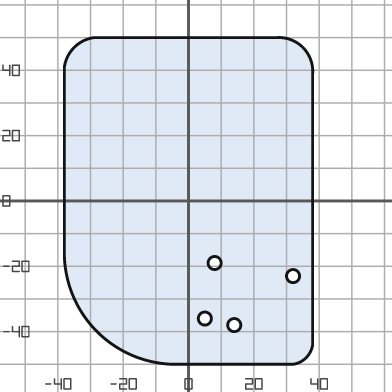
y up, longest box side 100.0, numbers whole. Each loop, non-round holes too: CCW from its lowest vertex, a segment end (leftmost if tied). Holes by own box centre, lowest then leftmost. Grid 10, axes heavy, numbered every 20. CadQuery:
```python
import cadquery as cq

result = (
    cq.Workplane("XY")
    .moveTo(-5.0, -50.0)
    .lineTo(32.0, -50.0)
    .threePointArc((36.0, -48.0), (38.0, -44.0))
    .lineTo(38.0, 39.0)
    .threePointArc((35.0, 47.0), (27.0, 50.0))
    .lineTo(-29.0, 50.0)
    .threePointArc((-35.0, 47.0), (-38.0, 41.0))
    .lineTo(-38.0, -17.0)
    .threePointArc((-28.0, -40.0), (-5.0, -50.0))
    .close()
    .moveTo(14.0, -38.0)
    .circle(2.0)
    .moveTo(5.0, -36.0)
    .circle(2.0)
    .moveTo(32.0, -23.0)
    .circle(2.0)
    .moveTo(8.0, -19.0)
    .circle(2.0)
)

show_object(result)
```